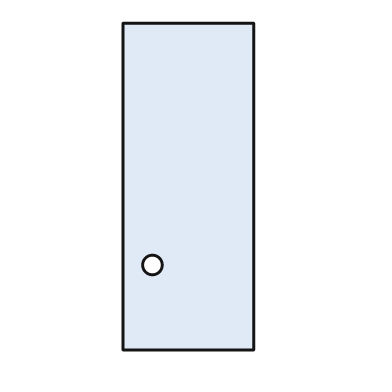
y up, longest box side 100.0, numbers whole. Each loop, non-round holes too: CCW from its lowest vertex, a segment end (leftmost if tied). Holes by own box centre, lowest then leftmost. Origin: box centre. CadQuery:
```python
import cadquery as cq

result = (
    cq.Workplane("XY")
    .moveTo(-20.0, -50.0)
    .lineTo(20.0, -50.0)
    .lineTo(20.0, 50.0)
    .lineTo(-20.0, 50.0)
    .close()
    .moveTo(-11.0, -24.0)
    .circle(3.0)
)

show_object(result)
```